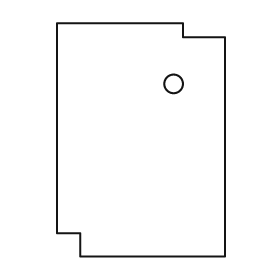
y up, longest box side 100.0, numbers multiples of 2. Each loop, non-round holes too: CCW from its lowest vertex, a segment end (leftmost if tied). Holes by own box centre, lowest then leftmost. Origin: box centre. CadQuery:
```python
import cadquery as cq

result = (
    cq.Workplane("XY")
    .moveTo(-26.0, -50.0)
    .lineTo(36.0, -50.0)
    .lineTo(36.0, 44.0)
    .lineTo(18.0, 44.0)
    .lineTo(18.0, 50.0)
    .lineTo(-36.0, 50.0)
    .lineTo(-36.0, -40.0)
    .lineTo(-26.0, -40.0)
    .close()
    .moveTo(14.0, 24.0)
    .circle(4.0)
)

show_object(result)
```